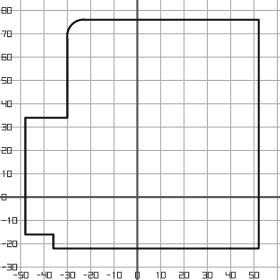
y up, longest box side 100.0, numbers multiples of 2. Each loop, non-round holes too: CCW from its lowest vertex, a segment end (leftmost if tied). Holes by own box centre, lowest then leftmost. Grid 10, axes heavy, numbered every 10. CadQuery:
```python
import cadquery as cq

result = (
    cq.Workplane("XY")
    .moveTo(-36.0, -22.0)
    .lineTo(52.0, -22.0)
    .lineTo(52.0, 76.0)
    .lineTo(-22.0, 76.0)
    .threePointArc((-28.0, 74.0), (-30.0, 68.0))
    .lineTo(-30.0, 34.0)
    .lineTo(-48.0, 34.0)
    .lineTo(-48.0, -16.0)
    .lineTo(-36.0, -16.0)
    .close()
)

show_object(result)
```